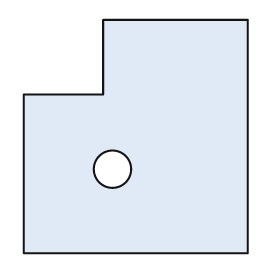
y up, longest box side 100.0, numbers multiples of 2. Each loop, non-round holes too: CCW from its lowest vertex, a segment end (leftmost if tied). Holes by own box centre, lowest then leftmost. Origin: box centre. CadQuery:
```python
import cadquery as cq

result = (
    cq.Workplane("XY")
    .moveTo(-48.0, -50.0)
    .lineTo(48.0, -50.0)
    .lineTo(48.0, 50.0)
    .lineTo(-14.0, 50.0)
    .lineTo(-14.0, 18.0)
    .lineTo(-48.0, 18.0)
    .close()
    .moveTo(-10.0, -14.0)
    .circle(8.0)
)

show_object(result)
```